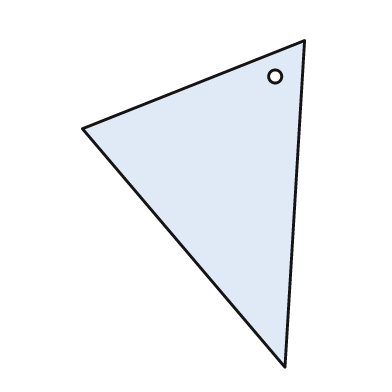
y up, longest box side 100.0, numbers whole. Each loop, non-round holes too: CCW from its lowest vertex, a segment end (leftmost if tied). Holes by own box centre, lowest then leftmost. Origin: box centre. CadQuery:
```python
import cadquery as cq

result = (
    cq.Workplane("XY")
    .moveTo(28.0, -50.0)
    .lineTo(34.0, 50.0)
    .lineTo(-34.0, 23.0)
    .close()
    .moveTo(25.0, 39.0)
    .circle(2.0)
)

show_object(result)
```